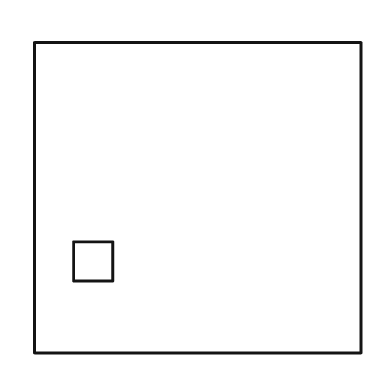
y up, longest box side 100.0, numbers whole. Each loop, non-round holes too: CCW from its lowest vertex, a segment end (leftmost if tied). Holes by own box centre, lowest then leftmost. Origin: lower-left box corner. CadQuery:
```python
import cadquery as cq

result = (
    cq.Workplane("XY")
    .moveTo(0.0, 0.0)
    .lineTo(100.0, 0.0)
    .lineTo(100.0, 95.0)
    .lineTo(0.0, 95.0)
    .close()
    .moveTo(12.0, 22.0)
    .lineTo(24.0, 22.0)
    .lineTo(24.0, 34.0)
    .lineTo(12.0, 34.0)
    .close()
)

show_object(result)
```